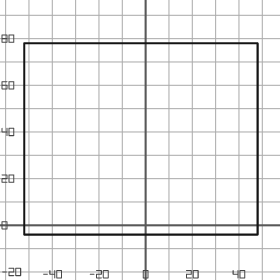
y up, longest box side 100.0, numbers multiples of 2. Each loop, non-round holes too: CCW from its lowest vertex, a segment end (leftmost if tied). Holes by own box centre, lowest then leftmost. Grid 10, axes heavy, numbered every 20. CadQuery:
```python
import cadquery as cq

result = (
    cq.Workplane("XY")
    .moveTo(-52.0, -4.0)
    .lineTo(48.0, -4.0)
    .lineTo(48.0, 78.0)
    .lineTo(-52.0, 78.0)
    .close()
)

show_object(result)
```